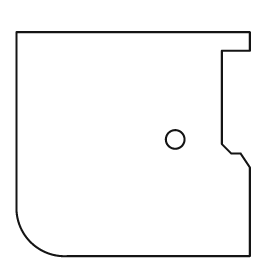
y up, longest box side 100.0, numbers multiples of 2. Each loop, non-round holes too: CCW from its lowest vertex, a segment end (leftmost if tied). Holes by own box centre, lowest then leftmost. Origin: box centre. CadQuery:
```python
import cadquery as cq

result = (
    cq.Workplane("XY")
    .moveTo(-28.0, -48.0)
    .lineTo(50.0, -48.0)
    .lineTo(50.0, -10.0)
    .lineTo(46.0, -4.0)
    .lineTo(42.0, -4.0)
    .lineTo(38.0, 0.0)
    .lineTo(38.0, 40.0)
    .lineTo(50.0, 40.0)
    .lineTo(50.0, 48.0)
    .lineTo(-50.0, 48.0)
    .lineTo(-50.0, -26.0)
    .threePointArc((-44.0, -42.0), (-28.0, -48.0))
    .close()
    .moveTo(18.0, 2.0)
    .circle(4.0)
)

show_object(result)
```